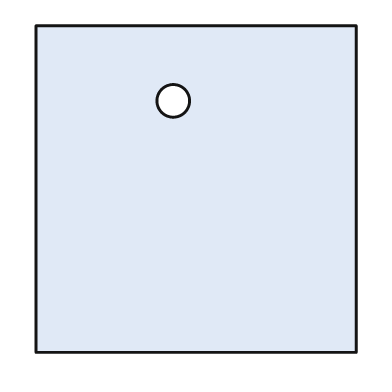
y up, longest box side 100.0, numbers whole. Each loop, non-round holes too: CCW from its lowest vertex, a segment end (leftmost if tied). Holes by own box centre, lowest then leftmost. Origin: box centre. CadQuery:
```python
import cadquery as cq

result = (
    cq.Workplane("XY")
    .moveTo(-49.0, -50.0)
    .lineTo(49.0, -50.0)
    .lineTo(49.0, 50.0)
    .lineTo(-49.0, 50.0)
    .close()
    .moveTo(-7.0, 27.0)
    .circle(5.0)
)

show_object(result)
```